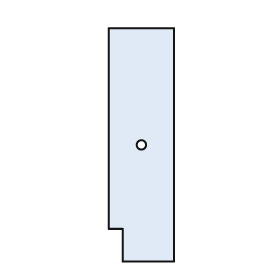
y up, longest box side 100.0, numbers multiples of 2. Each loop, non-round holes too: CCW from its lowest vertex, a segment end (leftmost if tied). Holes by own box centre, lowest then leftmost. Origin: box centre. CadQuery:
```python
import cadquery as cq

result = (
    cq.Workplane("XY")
    .moveTo(-8.0, -50.0)
    .lineTo(14.0, -50.0)
    .lineTo(14.0, 50.0)
    .lineTo(-14.0, 50.0)
    .lineTo(-14.0, -36.0)
    .lineTo(-8.0, -36.0)
    .close()
    .moveTo(0.0, 0.0)
    .circle(2.0)
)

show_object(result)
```